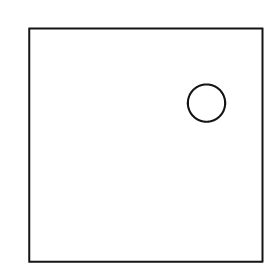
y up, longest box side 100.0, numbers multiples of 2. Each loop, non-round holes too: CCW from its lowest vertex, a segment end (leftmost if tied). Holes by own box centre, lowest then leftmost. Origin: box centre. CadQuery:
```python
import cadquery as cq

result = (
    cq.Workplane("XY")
    .moveTo(-50.0, -50.0)
    .lineTo(50.0, -50.0)
    .lineTo(50.0, 50.0)
    .lineTo(-50.0, 50.0)
    .close()
    .moveTo(26.0, 18.0)
    .circle(8.0)
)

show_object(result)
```